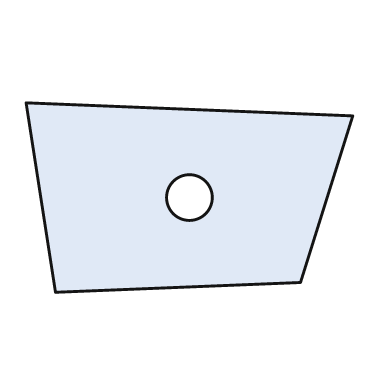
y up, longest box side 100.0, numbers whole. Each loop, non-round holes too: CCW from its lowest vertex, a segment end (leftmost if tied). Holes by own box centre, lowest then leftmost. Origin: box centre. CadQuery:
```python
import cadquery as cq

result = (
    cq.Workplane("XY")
    .moveTo(-41.0, -29.0)
    .lineTo(34.0, -26.0)
    .lineTo(50.0, 25.0)
    .lineTo(-50.0, 29.0)
    .close()
    .moveTo(0.0, 0.0)
    .circle(7.0)
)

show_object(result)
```